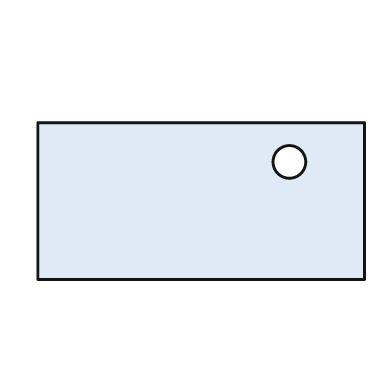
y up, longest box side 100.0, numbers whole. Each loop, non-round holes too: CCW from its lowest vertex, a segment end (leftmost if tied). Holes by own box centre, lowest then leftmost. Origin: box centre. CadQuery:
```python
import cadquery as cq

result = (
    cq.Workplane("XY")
    .moveTo(-50.0, -24.0)
    .lineTo(50.0, -24.0)
    .lineTo(50.0, 24.0)
    .lineTo(-50.0, 24.0)
    .close()
    .moveTo(27.0, 12.0)
    .circle(5.0)
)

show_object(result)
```